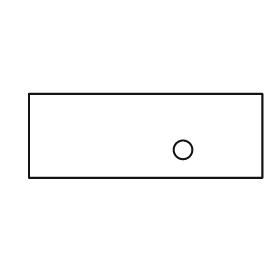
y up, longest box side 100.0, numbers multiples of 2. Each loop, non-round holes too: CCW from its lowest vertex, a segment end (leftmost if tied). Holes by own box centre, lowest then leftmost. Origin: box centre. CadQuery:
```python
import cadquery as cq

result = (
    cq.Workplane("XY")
    .moveTo(-50.0, -18.0)
    .lineTo(50.0, -18.0)
    .lineTo(50.0, 18.0)
    .lineTo(-50.0, 18.0)
    .close()
    .moveTo(16.0, -6.0)
    .circle(4.0)
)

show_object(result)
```